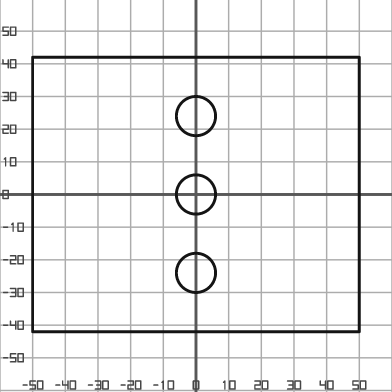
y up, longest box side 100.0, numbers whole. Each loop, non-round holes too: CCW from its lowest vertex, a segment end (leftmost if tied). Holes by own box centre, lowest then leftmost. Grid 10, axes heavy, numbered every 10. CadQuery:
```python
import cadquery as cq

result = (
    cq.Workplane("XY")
    .moveTo(-50.0, -42.0)
    .lineTo(50.0, -42.0)
    .lineTo(50.0, 42.0)
    .lineTo(-50.0, 42.0)
    .close()
    .moveTo(0.0, -24.0)
    .circle(6.0)
    .moveTo(0.0, 0.0)
    .circle(6.0)
    .moveTo(0.0, 24.0)
    .circle(6.0)
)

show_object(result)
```